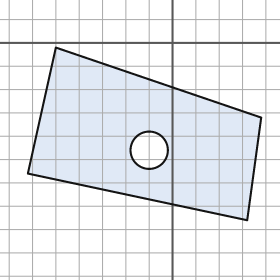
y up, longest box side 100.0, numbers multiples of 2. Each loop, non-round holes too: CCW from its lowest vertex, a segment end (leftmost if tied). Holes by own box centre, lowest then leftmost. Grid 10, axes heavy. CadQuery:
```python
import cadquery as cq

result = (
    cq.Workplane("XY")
    .moveTo(32.0, -76.0)
    .lineTo(38.0, -32.0)
    .lineTo(-50.0, -2.0)
    .lineTo(-62.0, -56.0)
    .close()
    .moveTo(-10.0, -46.0)
    .circle(8.0)
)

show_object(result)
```